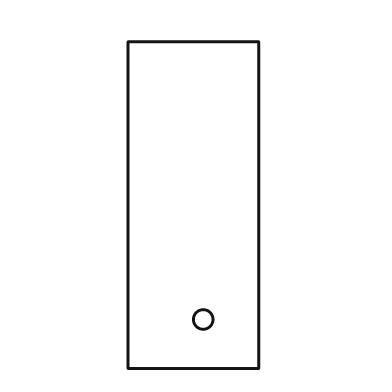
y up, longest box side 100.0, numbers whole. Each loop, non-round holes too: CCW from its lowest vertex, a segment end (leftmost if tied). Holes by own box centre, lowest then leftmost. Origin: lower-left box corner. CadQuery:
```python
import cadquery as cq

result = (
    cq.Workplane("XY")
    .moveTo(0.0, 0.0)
    .lineTo(40.0, 0.0)
    .lineTo(40.0, 100.0)
    .lineTo(0.0, 100.0)
    .close()
    .moveTo(23.0, 15.0)
    .circle(3.0)
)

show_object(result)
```